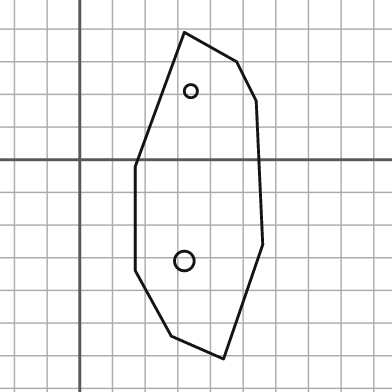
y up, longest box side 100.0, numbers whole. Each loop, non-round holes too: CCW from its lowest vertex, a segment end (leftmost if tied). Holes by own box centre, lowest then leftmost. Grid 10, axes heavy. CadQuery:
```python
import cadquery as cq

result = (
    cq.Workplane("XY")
    .moveTo(44.0, -61.0)
    .lineTo(56.0, -26.0)
    .lineTo(54.0, 18.0)
    .lineTo(48.0, 30.0)
    .lineTo(32.0, 39.0)
    .lineTo(17.0, -2.0)
    .lineTo(17.0, -34.0)
    .lineTo(28.0, -54.0)
    .close()
    .moveTo(32.0, -31.0)
    .circle(3.0)
    .moveTo(34.0, 21.0)
    .circle(2.0)
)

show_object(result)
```